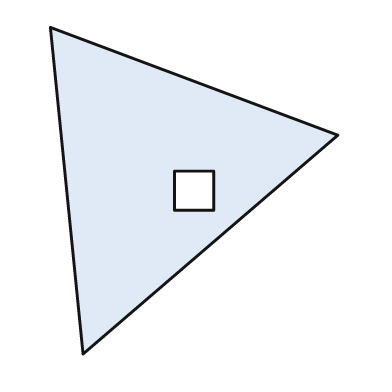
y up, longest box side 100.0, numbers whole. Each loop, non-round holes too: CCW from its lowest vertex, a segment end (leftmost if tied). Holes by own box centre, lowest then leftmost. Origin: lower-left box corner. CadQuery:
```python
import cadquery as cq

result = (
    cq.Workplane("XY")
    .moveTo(10.0, 0.0)
    .lineTo(88.0, 67.0)
    .lineTo(0.0, 100.0)
    .close()
    .moveTo(38.0, 44.0)
    .lineTo(50.0, 44.0)
    .lineTo(50.0, 56.0)
    .lineTo(38.0, 56.0)
    .close()
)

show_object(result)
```